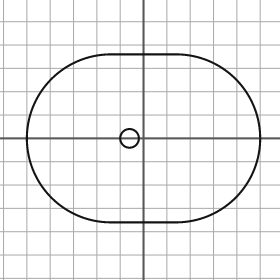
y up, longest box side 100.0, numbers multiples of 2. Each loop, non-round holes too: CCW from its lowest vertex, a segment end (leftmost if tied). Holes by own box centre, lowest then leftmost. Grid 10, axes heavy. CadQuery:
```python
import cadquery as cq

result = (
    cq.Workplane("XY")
    .moveTo(-14.0, -36.0)
    .lineTo(14.0, -36.0)
    .threePointArc((50.0, 0.0), (14.0, 36.0))
    .lineTo(-14.0, 36.0)
    .threePointArc((-50.0, 0.0), (-14.0, -36.0))
    .close()
    .moveTo(-6.0, 0.0)
    .circle(4.0)
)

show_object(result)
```